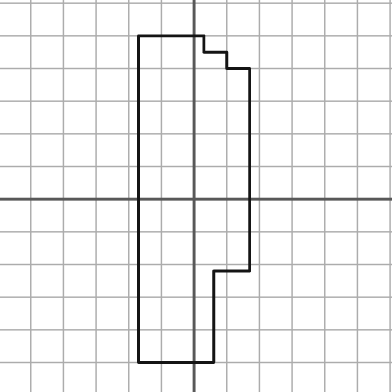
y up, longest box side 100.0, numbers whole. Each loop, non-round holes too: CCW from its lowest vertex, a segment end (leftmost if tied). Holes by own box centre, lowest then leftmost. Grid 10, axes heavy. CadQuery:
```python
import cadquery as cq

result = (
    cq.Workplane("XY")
    .moveTo(-17.0, -50.0)
    .lineTo(6.0, -50.0)
    .lineTo(6.0, -22.0)
    .lineTo(17.0, -22.0)
    .lineTo(17.0, 40.0)
    .lineTo(10.0, 40.0)
    .lineTo(10.0, 45.0)
    .lineTo(3.0, 45.0)
    .lineTo(3.0, 50.0)
    .lineTo(-17.0, 50.0)
    .close()
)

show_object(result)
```